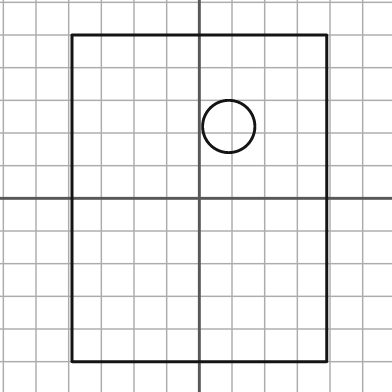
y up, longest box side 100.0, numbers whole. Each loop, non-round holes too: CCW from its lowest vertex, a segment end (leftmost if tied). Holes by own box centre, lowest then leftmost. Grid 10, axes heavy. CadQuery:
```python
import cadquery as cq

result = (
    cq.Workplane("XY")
    .moveTo(-39.0, -50.0)
    .lineTo(39.0, -50.0)
    .lineTo(39.0, 50.0)
    .lineTo(-39.0, 50.0)
    .close()
    .moveTo(9.0, 22.0)
    .circle(8.0)
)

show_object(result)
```